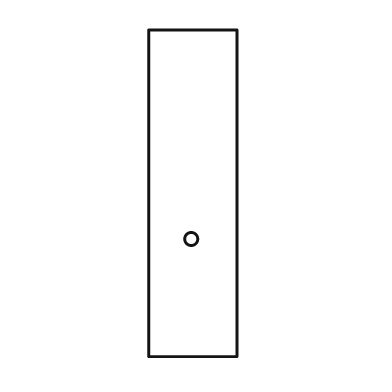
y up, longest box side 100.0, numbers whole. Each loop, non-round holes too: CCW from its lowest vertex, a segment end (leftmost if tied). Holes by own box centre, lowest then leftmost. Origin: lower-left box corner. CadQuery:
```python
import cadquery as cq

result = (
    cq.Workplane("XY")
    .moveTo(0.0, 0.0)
    .lineTo(27.0, 0.0)
    .lineTo(27.0, 100.0)
    .lineTo(0.0, 100.0)
    .close()
    .moveTo(13.0, 36.0)
    .circle(2.0)
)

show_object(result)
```